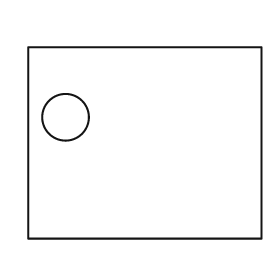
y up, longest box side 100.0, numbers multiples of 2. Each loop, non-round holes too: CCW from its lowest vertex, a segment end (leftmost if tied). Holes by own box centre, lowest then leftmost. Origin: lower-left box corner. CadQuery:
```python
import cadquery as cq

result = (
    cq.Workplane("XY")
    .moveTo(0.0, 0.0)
    .lineTo(100.0, 0.0)
    .lineTo(100.0, 82.0)
    .lineTo(0.0, 82.0)
    .close()
    .moveTo(16.0, 52.0)
    .circle(10.0)
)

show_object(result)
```